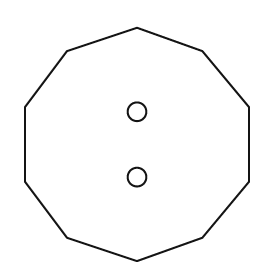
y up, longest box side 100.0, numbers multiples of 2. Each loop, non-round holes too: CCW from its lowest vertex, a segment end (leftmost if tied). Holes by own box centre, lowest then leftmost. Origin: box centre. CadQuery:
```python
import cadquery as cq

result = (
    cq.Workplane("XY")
    .moveTo(0.0, -50.0)
    .lineTo(28.0, -40.0)
    .lineTo(48.0, -16.0)
    .lineTo(48.0, 16.0)
    .lineTo(28.0, 40.0)
    .lineTo(0.0, 50.0)
    .lineTo(-30.0, 40.0)
    .lineTo(-48.0, 16.0)
    .lineTo(-48.0, -16.0)
    .lineTo(-30.0, -40.0)
    .close()
    .moveTo(0.0, -14.0)
    .circle(4.0)
    .moveTo(0.0, 14.0)
    .circle(4.0)
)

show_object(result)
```